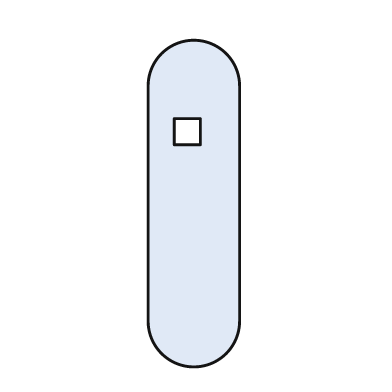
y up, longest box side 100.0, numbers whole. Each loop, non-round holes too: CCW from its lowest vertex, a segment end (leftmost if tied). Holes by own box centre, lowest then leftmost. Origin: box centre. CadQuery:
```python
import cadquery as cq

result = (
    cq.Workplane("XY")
    .moveTo(-14.0, -36.0)
    .threePointArc((0.0, -50.0), (14.0, -36.0))
    .lineTo(14.0, 36.0)
    .threePointArc((0.0, 50.0), (-14.0, 36.0))
    .close()
    .moveTo(-6.0, 18.0)
    .lineTo(2.0, 18.0)
    .lineTo(2.0, 26.0)
    .lineTo(-6.0, 26.0)
    .close()
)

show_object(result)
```